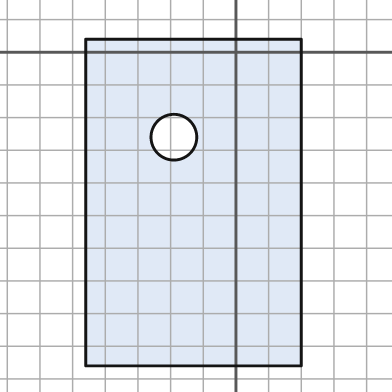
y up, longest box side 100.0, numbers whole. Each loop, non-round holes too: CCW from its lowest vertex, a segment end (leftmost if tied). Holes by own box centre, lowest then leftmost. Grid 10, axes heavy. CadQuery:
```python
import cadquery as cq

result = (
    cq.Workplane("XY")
    .moveTo(-46.0, -96.0)
    .lineTo(20.0, -96.0)
    .lineTo(20.0, 4.0)
    .lineTo(-46.0, 4.0)
    .close()
    .moveTo(-19.0, -26.0)
    .circle(7.0)
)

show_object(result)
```